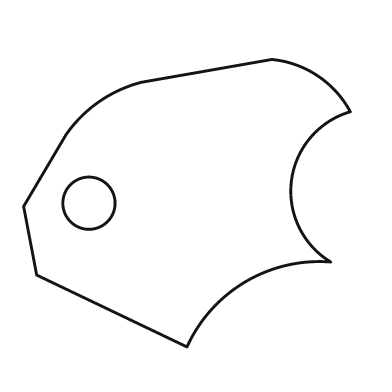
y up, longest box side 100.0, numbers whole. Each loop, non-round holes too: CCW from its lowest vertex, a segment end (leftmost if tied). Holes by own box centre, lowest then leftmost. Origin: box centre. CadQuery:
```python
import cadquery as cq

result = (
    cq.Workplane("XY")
    .moveTo(0.0, -44.0)
    .threePointArc((18.0, -24.0), (44.0, -18.0))
    .threePointArc((32.0, 7.0), (50.0, 28.0))
    .threePointArc((40.0, 39.0), (26.0, 44.0))
    .lineTo(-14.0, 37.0)
    .threePointArc((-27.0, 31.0), (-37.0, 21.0))
    .lineTo(-50.0, -1.0)
    .lineTo(-46.0, -22.0)
    .close()
    .moveTo(-30.0, 0.0)
    .circle(8.0)
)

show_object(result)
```